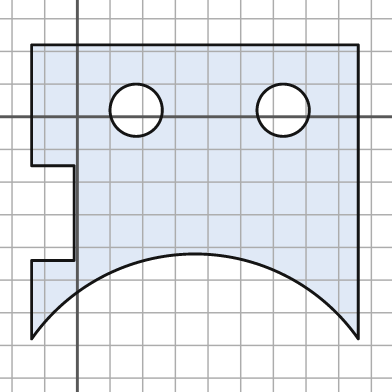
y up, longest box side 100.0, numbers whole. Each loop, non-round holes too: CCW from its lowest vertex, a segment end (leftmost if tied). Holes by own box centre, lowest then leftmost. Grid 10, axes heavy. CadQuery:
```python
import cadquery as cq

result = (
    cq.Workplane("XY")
    .moveTo(-14.0, -68.0)
    .threePointArc((36.0, -42.0), (86.0, -68.0))
    .lineTo(86.0, 22.0)
    .lineTo(-14.0, 22.0)
    .lineTo(-14.0, -15.0)
    .lineTo(-1.0, -15.0)
    .lineTo(-1.0, -44.0)
    .lineTo(-14.0, -44.0)
    .close()
    .moveTo(18.0, 2.0)
    .circle(8.0)
    .moveTo(63.0, 2.0)
    .circle(8.0)
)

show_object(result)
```